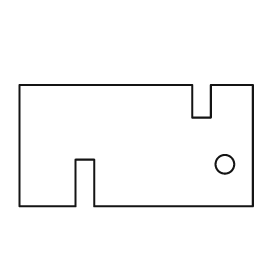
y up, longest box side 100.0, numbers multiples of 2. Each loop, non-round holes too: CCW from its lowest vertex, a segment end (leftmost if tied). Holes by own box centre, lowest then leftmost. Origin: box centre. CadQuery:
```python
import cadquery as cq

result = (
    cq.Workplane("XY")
    .moveTo(-50.0, -26.0)
    .lineTo(-26.0, -26.0)
    .lineTo(-26.0, -6.0)
    .lineTo(-18.0, -6.0)
    .lineTo(-18.0, -26.0)
    .lineTo(50.0, -26.0)
    .lineTo(50.0, 26.0)
    .lineTo(32.0, 26.0)
    .lineTo(32.0, 12.0)
    .lineTo(24.0, 12.0)
    .lineTo(24.0, 26.0)
    .lineTo(-50.0, 26.0)
    .close()
    .moveTo(38.0, -8.0)
    .circle(4.0)
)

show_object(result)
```